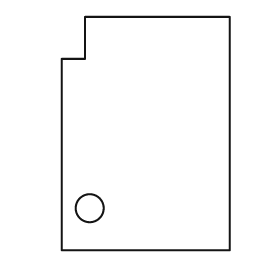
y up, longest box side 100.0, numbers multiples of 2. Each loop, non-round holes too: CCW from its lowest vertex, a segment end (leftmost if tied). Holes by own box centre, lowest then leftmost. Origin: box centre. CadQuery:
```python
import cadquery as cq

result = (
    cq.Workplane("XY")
    .moveTo(-36.0, -50.0)
    .lineTo(36.0, -50.0)
    .lineTo(36.0, 50.0)
    .lineTo(-26.0, 50.0)
    .lineTo(-26.0, 32.0)
    .lineTo(-36.0, 32.0)
    .close()
    .moveTo(-24.0, -32.0)
    .circle(6.0)
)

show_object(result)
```